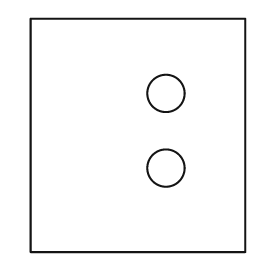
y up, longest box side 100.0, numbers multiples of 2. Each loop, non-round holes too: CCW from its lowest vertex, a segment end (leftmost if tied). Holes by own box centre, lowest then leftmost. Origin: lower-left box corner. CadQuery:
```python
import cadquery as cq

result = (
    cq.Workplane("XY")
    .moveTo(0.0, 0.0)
    .lineTo(92.0, 0.0)
    .lineTo(92.0, 100.0)
    .lineTo(0.0, 100.0)
    .close()
    .moveTo(58.0, 36.0)
    .circle(8.0)
    .moveTo(58.0, 68.0)
    .circle(8.0)
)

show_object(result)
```